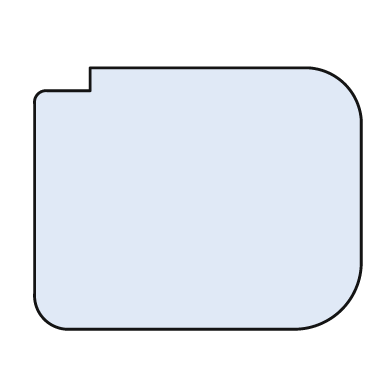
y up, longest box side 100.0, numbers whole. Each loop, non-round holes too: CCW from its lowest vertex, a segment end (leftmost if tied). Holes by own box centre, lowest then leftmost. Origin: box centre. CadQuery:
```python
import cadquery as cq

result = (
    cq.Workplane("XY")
    .moveTo(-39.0, -40.0)
    .lineTo(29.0, -40.0)
    .threePointArc((44.0, -34.0), (50.0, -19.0))
    .lineTo(50.0, 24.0)
    .threePointArc((45.0, 35.0), (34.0, 40.0))
    .lineTo(-33.0, 40.0)
    .lineTo(-33.0, 33.0)
    .lineTo(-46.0, 33.0)
    .threePointArc((-49.0, 32.0), (-50.0, 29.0))
    .lineTo(-50.0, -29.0)
    .threePointArc((-47.0, -37.0), (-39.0, -40.0))
    .close()
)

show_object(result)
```